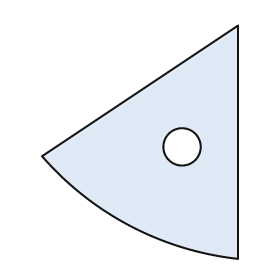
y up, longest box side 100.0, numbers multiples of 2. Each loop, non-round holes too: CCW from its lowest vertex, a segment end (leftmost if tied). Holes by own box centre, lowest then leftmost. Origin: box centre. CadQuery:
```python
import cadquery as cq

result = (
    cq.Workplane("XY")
    .moveTo(42.0, -50.0)
    .lineTo(42.0, 50.0)
    .lineTo(-42.0, -6.0)
    .threePointArc((-4.0, -36.0), (42.0, -50.0))
    .close()
    .moveTo(18.0, -2.0)
    .circle(8.0)
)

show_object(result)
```